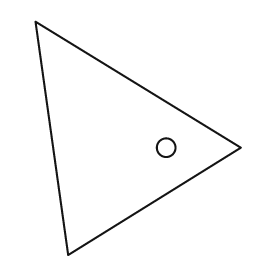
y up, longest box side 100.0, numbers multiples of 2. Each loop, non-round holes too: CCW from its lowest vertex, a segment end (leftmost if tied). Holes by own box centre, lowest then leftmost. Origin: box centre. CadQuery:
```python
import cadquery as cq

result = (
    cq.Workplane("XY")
    .moveTo(-30.0, -50.0)
    .lineTo(44.0, -4.0)
    .lineTo(-44.0, 50.0)
    .close()
    .moveTo(12.0, -4.0)
    .circle(4.0)
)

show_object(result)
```